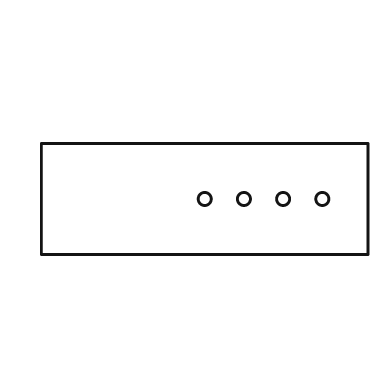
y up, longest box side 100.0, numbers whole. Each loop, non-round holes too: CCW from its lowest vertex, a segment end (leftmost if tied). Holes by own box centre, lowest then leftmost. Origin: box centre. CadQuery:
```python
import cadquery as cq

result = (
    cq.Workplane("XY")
    .moveTo(-50.0, -17.0)
    .lineTo(50.0, -17.0)
    .lineTo(50.0, 17.0)
    .lineTo(-50.0, 17.0)
    .close()
    .moveTo(0.0, 0.0)
    .circle(2.0)
    .moveTo(12.0, 0.0)
    .circle(2.0)
    .moveTo(24.0, 0.0)
    .circle(2.0)
    .moveTo(36.0, 0.0)
    .circle(2.0)
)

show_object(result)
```